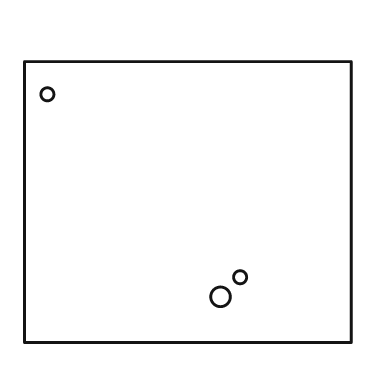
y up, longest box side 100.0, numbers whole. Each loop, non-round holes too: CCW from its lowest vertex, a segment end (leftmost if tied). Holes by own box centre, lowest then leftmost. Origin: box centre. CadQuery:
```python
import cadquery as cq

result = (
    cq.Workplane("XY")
    .moveTo(-50.0, -43.0)
    .lineTo(50.0, -43.0)
    .lineTo(50.0, 43.0)
    .lineTo(-50.0, 43.0)
    .close()
    .moveTo(10.0, -29.0)
    .circle(3.0)
    .moveTo(16.0, -23.0)
    .circle(2.0)
    .moveTo(-43.0, 33.0)
    .circle(2.0)
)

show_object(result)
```